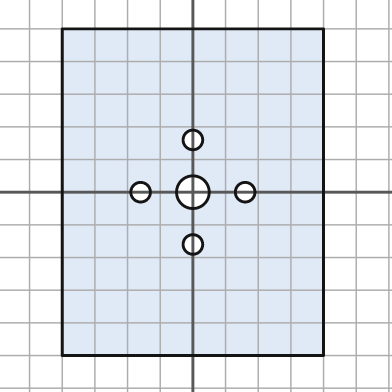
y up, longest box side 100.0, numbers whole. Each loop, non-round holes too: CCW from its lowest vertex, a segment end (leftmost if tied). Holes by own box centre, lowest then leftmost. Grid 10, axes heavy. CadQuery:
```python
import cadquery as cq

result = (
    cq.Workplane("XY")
    .moveTo(-40.0, -50.0)
    .lineTo(40.0, -50.0)
    .lineTo(40.0, 50.0)
    .lineTo(-40.0, 50.0)
    .close()
    .moveTo(0.0, -16.0)
    .circle(3.0)
    .moveTo(-16.0, 0.0)
    .circle(3.0)
    .moveTo(0.0, 0.0)
    .circle(5.0)
    .moveTo(16.0, 0.0)
    .circle(3.0)
    .moveTo(0.0, 16.0)
    .circle(3.0)
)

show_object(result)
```